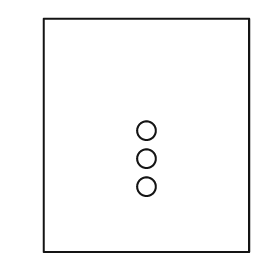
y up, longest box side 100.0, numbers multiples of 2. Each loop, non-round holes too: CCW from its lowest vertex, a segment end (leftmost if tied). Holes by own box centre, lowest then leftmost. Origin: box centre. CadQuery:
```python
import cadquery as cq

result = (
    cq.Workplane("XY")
    .moveTo(-44.0, -50.0)
    .lineTo(44.0, -50.0)
    .lineTo(44.0, 50.0)
    .lineTo(-44.0, 50.0)
    .close()
    .moveTo(0.0, -22.0)
    .circle(4.0)
    .moveTo(0.0, -10.0)
    .circle(4.0)
    .moveTo(0.0, 2.0)
    .circle(4.0)
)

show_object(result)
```